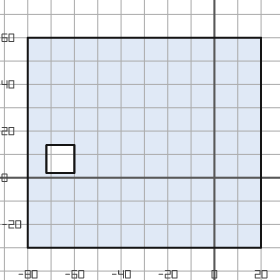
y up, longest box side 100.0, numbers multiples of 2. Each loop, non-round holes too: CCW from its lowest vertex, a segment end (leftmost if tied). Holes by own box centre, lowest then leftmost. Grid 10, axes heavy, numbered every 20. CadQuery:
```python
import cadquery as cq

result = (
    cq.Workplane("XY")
    .moveTo(-80.0, -30.0)
    .lineTo(20.0, -30.0)
    .lineTo(20.0, 60.0)
    .lineTo(-80.0, 60.0)
    .close()
    .moveTo(-72.0, 2.0)
    .lineTo(-60.0, 2.0)
    .lineTo(-60.0, 14.0)
    .lineTo(-72.0, 14.0)
    .close()
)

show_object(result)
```